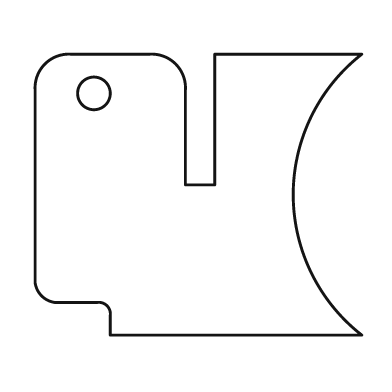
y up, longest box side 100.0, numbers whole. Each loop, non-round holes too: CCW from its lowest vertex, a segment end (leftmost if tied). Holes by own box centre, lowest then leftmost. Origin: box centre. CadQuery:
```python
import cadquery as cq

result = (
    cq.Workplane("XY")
    .moveTo(-27.0, -43.0)
    .lineTo(50.0, -43.0)
    .threePointArc((29.0, 0.0), (50.0, 43.0))
    .lineTo(5.0, 43.0)
    .lineTo(5.0, 3.0)
    .lineTo(-4.0, 3.0)
    .lineTo(-4.0, 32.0)
    .threePointArc((-7.0, 40.0), (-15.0, 43.0))
    .lineTo(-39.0, 43.0)
    .threePointArc((-47.0, 40.0), (-50.0, 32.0))
    .lineTo(-50.0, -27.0)
    .threePointArc((-48.0, -31.0), (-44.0, -33.0))
    .lineTo(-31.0, -33.0)
    .threePointArc((-28.0, -34.0), (-27.0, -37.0))
    .close()
    .moveTo(-32.0, 31.0)
    .circle(5.0)
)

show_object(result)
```